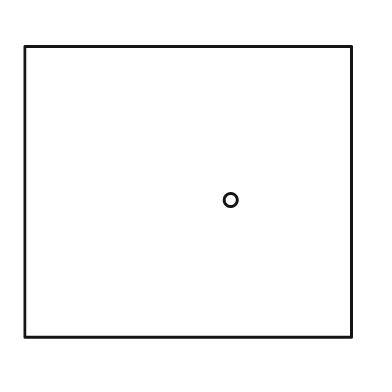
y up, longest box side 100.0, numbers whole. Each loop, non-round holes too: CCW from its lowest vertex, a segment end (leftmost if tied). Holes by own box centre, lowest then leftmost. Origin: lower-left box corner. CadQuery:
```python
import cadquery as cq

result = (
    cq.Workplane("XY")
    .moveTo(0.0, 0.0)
    .lineTo(100.0, 0.0)
    .lineTo(100.0, 89.0)
    .lineTo(0.0, 89.0)
    .close()
    .moveTo(63.0, 42.0)
    .circle(2.0)
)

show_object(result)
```